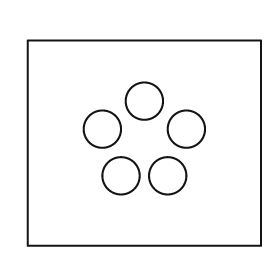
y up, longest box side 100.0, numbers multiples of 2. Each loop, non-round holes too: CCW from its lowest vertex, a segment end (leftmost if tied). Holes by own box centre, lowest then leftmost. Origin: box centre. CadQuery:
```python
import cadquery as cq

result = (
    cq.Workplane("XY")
    .moveTo(-50.0, -44.0)
    .lineTo(50.0, -44.0)
    .lineTo(50.0, 44.0)
    .lineTo(-50.0, 44.0)
    .close()
    .moveTo(-10.0, -14.0)
    .circle(8.0)
    .moveTo(10.0, -14.0)
    .circle(8.0)
    .moveTo(-18.0, 6.0)
    .circle(8.0)
    .moveTo(18.0, 6.0)
    .circle(8.0)
    .moveTo(0.0, 18.0)
    .circle(8.0)
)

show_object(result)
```